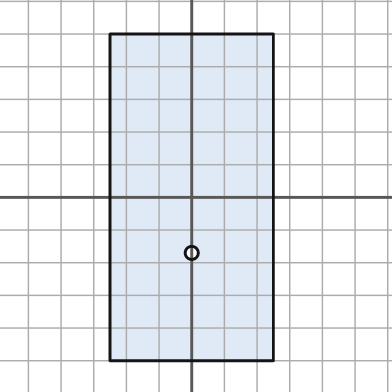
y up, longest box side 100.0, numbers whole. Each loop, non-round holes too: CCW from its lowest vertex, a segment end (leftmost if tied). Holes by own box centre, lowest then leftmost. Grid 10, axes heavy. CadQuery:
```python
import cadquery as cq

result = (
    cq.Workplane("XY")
    .moveTo(-25.0, -50.0)
    .lineTo(25.0, -50.0)
    .lineTo(25.0, 50.0)
    .lineTo(-25.0, 50.0)
    .close()
    .moveTo(0.0, -17.0)
    .circle(2.0)
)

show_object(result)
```